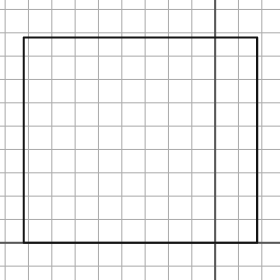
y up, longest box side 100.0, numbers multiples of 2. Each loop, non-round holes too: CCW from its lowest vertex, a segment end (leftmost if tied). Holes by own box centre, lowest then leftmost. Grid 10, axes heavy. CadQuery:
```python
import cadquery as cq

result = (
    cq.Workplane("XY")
    .moveTo(-82.0, 0.0)
    .lineTo(18.0, 0.0)
    .lineTo(18.0, 88.0)
    .lineTo(-82.0, 88.0)
    .close()
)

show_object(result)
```